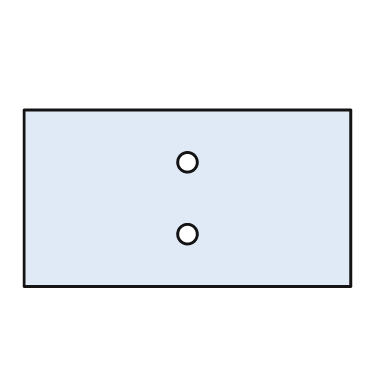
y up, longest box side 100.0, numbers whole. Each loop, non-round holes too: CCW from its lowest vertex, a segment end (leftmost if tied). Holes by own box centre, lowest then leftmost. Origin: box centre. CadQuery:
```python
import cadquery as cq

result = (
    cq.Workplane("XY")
    .moveTo(-50.0, -27.0)
    .lineTo(50.0, -27.0)
    .lineTo(50.0, 27.0)
    .lineTo(-50.0, 27.0)
    .close()
    .moveTo(0.0, -11.0)
    .circle(3.0)
    .moveTo(0.0, 11.0)
    .circle(3.0)
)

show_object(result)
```